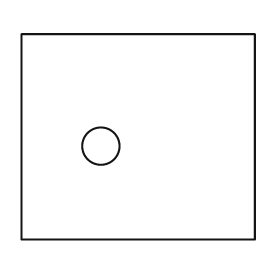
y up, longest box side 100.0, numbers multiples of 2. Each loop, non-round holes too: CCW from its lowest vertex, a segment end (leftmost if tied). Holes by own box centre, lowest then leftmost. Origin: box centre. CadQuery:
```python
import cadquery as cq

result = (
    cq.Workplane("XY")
    .moveTo(-50.0, -44.0)
    .lineTo(50.0, -44.0)
    .lineTo(50.0, 44.0)
    .lineTo(-50.0, 44.0)
    .close()
    .moveTo(-16.0, -4.0)
    .circle(8.0)
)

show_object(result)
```